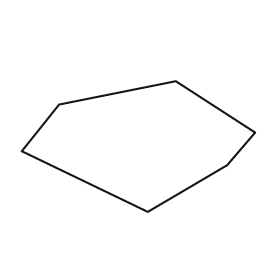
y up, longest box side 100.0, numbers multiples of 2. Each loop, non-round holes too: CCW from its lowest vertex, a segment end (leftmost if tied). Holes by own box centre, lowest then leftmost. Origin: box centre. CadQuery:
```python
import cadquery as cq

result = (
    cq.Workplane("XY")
    .moveTo(4.0, -28.0)
    .lineTo(38.0, -8.0)
    .lineTo(50.0, 6.0)
    .lineTo(16.0, 28.0)
    .lineTo(-34.0, 18.0)
    .lineTo(-50.0, -2.0)
    .close()
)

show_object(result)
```